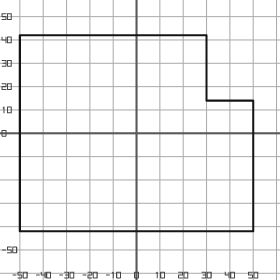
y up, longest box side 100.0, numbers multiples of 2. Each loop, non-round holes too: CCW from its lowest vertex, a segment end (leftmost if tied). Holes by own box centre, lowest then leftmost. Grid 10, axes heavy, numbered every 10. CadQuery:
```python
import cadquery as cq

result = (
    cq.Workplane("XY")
    .moveTo(-50.0, -42.0)
    .lineTo(50.0, -42.0)
    .lineTo(50.0, 14.0)
    .lineTo(30.0, 14.0)
    .lineTo(30.0, 42.0)
    .lineTo(-50.0, 42.0)
    .close()
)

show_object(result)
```